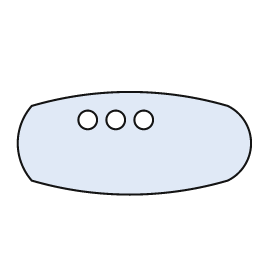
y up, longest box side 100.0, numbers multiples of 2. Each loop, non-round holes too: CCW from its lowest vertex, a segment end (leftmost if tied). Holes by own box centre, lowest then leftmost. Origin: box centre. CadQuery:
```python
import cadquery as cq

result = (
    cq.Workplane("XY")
    .moveTo(-44.0, -16.0)
    .threePointArc((-2.0, -22.0), (40.0, -16.0))
    .threePointArc((50.0, 0.0), (40.0, 16.0))
    .threePointArc((-2.0, 22.0), (-44.0, 16.0))
    .threePointArc((-50.0, 0.0), (-44.0, -16.0))
    .close()
    .moveTo(-20.0, 10.0)
    .circle(4.0)
    .moveTo(-8.0, 10.0)
    .circle(4.0)
    .moveTo(4.0, 10.0)
    .circle(4.0)
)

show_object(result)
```